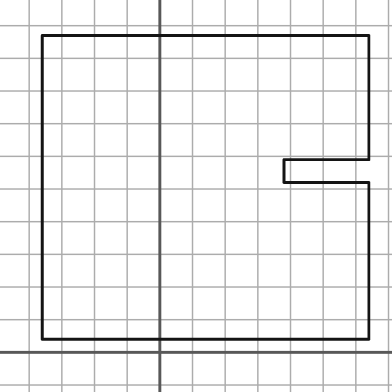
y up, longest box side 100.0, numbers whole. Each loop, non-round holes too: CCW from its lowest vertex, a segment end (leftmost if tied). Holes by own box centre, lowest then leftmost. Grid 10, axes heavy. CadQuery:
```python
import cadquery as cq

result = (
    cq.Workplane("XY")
    .moveTo(-36.0, 4.0)
    .lineTo(64.0, 4.0)
    .lineTo(64.0, 52.0)
    .lineTo(38.0, 52.0)
    .lineTo(38.0, 59.0)
    .lineTo(64.0, 59.0)
    .lineTo(64.0, 97.0)
    .lineTo(-36.0, 97.0)
    .close()
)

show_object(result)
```